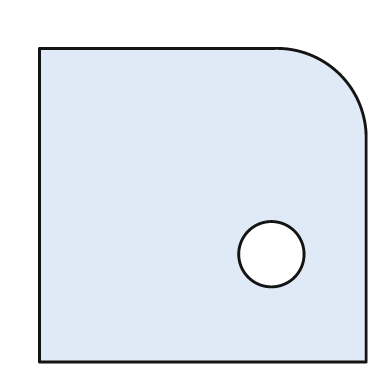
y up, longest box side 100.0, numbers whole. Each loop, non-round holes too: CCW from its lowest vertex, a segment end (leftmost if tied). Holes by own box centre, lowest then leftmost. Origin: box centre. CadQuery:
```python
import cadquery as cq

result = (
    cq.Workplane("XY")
    .moveTo(-50.0, -48.0)
    .lineTo(50.0, -48.0)
    .lineTo(50.0, 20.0)
    .threePointArc((42.0, 40.0), (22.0, 48.0))
    .lineTo(-50.0, 48.0)
    .close()
    .moveTo(21.0, -15.0)
    .circle(10.0)
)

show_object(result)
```